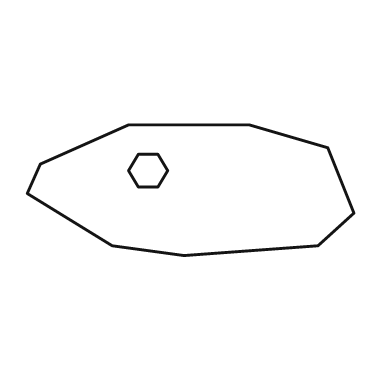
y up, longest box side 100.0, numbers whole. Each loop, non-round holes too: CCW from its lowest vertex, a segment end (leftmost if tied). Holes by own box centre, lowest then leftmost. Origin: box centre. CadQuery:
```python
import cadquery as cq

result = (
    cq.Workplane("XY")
    .moveTo(-2.0, -20.0)
    .lineTo(39.0, -17.0)
    .lineTo(50.0, -7.0)
    .lineTo(42.0, 13.0)
    .lineTo(18.0, 20.0)
    .lineTo(-19.0, 20.0)
    .lineTo(-46.0, 8.0)
    .lineTo(-50.0, -1.0)
    .lineTo(-24.0, -17.0)
    .close()
    .moveTo(-16.0, 1.0)
    .lineTo(-10.0, 1.0)
    .lineTo(-7.0, 6.0)
    .lineTo(-10.0, 11.0)
    .lineTo(-16.0, 11.0)
    .lineTo(-19.0, 6.0)
    .close()
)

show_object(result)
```